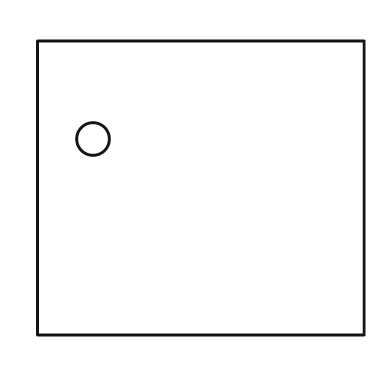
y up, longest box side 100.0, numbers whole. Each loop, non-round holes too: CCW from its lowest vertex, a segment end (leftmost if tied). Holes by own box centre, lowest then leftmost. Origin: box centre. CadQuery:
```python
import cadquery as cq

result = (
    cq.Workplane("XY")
    .moveTo(-50.0, -45.0)
    .lineTo(50.0, -45.0)
    .lineTo(50.0, 45.0)
    .lineTo(-50.0, 45.0)
    .close()
    .moveTo(-33.0, 15.0)
    .circle(5.0)
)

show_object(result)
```